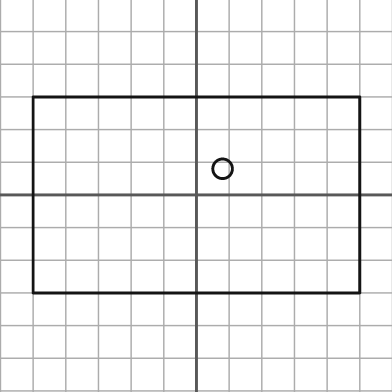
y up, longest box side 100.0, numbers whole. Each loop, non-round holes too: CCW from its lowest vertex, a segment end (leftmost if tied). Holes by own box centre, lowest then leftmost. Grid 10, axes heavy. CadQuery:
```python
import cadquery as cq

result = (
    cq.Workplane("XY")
    .moveTo(-50.0, -30.0)
    .lineTo(50.0, -30.0)
    .lineTo(50.0, 30.0)
    .lineTo(-50.0, 30.0)
    .close()
    .moveTo(8.0, 8.0)
    .circle(3.0)
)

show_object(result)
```